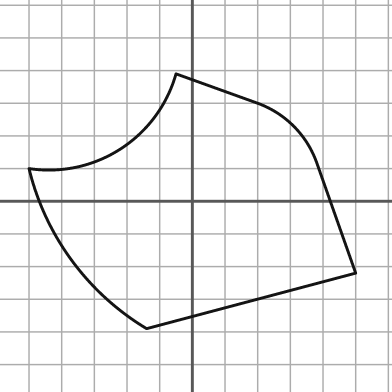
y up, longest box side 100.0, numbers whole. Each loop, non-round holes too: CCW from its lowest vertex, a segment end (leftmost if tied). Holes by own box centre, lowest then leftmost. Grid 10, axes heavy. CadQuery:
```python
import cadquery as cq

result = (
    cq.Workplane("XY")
    .moveTo(-14.0, -39.0)
    .lineTo(50.0, -22.0)
    .lineTo(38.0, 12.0)
    .threePointArc((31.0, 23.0), (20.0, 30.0))
    .lineTo(-5.0, 39.0)
    .threePointArc((-22.0, 16.0), (-50.0, 10.0))
    .threePointArc((-37.0, -18.0), (-14.0, -39.0))
    .close()
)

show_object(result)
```